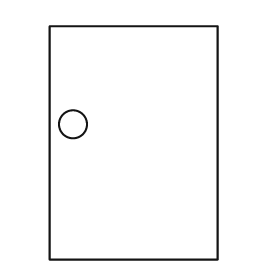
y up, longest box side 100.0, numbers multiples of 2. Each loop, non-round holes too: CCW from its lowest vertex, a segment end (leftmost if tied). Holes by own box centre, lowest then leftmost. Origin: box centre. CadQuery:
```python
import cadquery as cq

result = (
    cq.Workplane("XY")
    .moveTo(-36.0, -50.0)
    .lineTo(36.0, -50.0)
    .lineTo(36.0, 50.0)
    .lineTo(-36.0, 50.0)
    .close()
    .moveTo(-26.0, 8.0)
    .circle(6.0)
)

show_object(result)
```